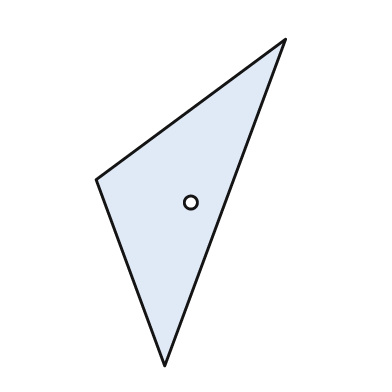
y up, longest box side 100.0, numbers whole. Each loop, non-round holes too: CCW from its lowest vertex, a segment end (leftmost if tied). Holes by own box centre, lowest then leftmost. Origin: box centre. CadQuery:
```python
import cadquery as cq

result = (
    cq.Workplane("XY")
    .moveTo(-8.0, -50.0)
    .lineTo(29.0, 50.0)
    .lineTo(-29.0, 7.0)
    .close()
    .moveTo(0.0, 0.0)
    .circle(2.0)
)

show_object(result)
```